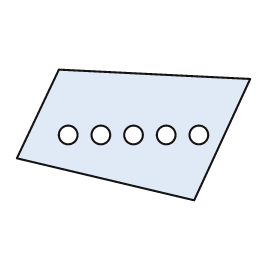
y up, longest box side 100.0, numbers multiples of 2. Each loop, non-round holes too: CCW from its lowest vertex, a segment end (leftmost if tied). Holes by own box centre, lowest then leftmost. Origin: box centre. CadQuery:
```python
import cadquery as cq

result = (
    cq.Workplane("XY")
    .moveTo(26.0, -28.0)
    .lineTo(50.0, 24.0)
    .lineTo(-32.0, 28.0)
    .lineTo(-50.0, -10.0)
    .close()
    .moveTo(-28.0, 0.0)
    .circle(4.0)
    .moveTo(-14.0, 0.0)
    .circle(4.0)
    .moveTo(0.0, 0.0)
    .circle(4.0)
    .moveTo(14.0, 0.0)
    .circle(4.0)
    .moveTo(28.0, 0.0)
    .circle(4.0)
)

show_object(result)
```